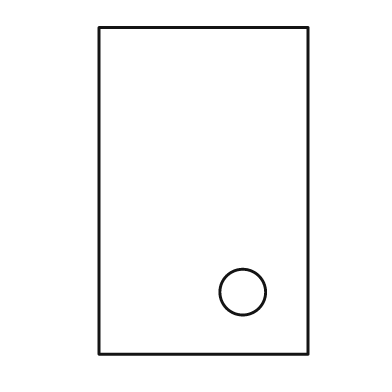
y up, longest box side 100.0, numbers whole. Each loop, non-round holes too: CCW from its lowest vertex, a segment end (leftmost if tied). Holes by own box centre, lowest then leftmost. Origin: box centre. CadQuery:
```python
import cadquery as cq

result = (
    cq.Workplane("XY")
    .moveTo(-32.0, -50.0)
    .lineTo(32.0, -50.0)
    .lineTo(32.0, 50.0)
    .lineTo(-32.0, 50.0)
    .close()
    .moveTo(12.0, -31.0)
    .circle(7.0)
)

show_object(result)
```